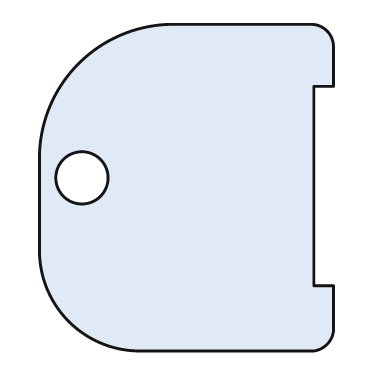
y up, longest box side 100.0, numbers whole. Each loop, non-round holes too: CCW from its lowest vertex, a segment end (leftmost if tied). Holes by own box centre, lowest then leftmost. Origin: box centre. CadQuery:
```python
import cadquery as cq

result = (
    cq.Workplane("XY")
    .moveTo(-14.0, -50.0)
    .lineTo(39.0, -50.0)
    .threePointArc((43.0, -48.0), (45.0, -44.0))
    .lineTo(45.0, -30.0)
    .lineTo(39.0, -30.0)
    .lineTo(39.0, 31.0)
    .lineTo(45.0, 31.0)
    .lineTo(45.0, 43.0)
    .threePointArc((43.0, 48.0), (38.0, 50.0))
    .lineTo(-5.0, 50.0)
    .threePointArc((-33.0, 38.0), (-45.0, 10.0))
    .lineTo(-45.0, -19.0)
    .threePointArc((-36.0, -41.0), (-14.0, -50.0))
    .close()
    .moveTo(-32.0, 3.0)
    .circle(8.0)
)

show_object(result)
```